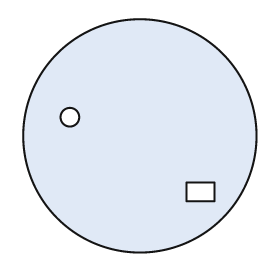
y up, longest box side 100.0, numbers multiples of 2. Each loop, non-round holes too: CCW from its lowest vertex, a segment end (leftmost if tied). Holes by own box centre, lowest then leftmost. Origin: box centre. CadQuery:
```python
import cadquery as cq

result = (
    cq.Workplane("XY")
    .moveTo(0.0, 0.0)
    .circle(50.0)
    .moveTo(20.0, -28.0)
    .lineTo(32.0, -28.0)
    .lineTo(32.0, -20.0)
    .lineTo(20.0, -20.0)
    .close()
    .moveTo(-30.0, 8.0)
    .circle(4.0)
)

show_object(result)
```